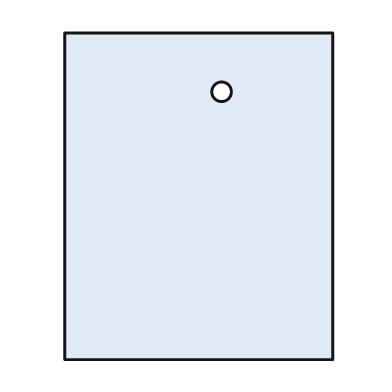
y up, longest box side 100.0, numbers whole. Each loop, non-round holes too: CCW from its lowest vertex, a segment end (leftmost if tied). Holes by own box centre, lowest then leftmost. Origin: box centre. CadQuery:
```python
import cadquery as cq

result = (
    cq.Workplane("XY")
    .moveTo(-41.0, -50.0)
    .lineTo(41.0, -50.0)
    .lineTo(41.0, 50.0)
    .lineTo(-41.0, 50.0)
    .close()
    .moveTo(7.0, 32.0)
    .circle(3.0)
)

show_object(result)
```